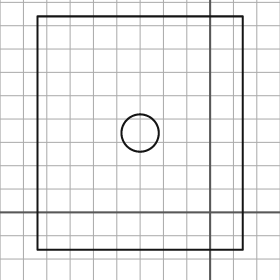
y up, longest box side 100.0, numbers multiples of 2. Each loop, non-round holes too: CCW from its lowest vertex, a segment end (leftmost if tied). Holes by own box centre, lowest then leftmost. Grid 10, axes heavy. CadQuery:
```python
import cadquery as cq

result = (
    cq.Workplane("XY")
    .moveTo(-74.0, -16.0)
    .lineTo(14.0, -16.0)
    .lineTo(14.0, 84.0)
    .lineTo(-74.0, 84.0)
    .close()
    .moveTo(-30.0, 34.0)
    .circle(8.0)
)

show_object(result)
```